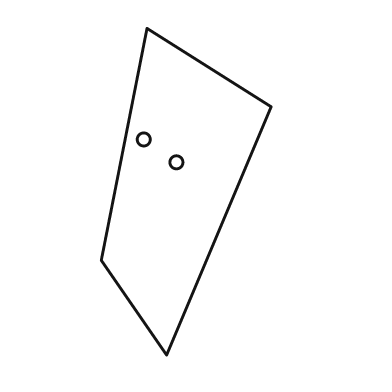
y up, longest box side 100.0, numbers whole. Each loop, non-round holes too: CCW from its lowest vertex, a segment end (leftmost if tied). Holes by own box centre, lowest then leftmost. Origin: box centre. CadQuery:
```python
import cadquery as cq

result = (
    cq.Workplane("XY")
    .moveTo(-6.0, -50.0)
    .lineTo(26.0, 26.0)
    .lineTo(-12.0, 50.0)
    .lineTo(-26.0, -21.0)
    .close()
    .moveTo(-3.0, 9.0)
    .circle(2.0)
    .moveTo(-13.0, 16.0)
    .circle(2.0)
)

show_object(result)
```